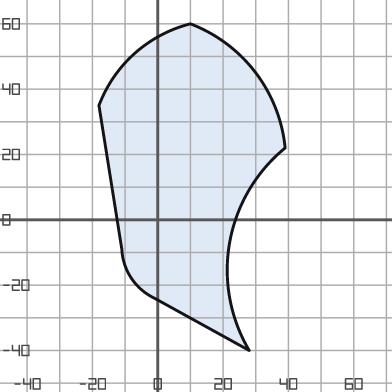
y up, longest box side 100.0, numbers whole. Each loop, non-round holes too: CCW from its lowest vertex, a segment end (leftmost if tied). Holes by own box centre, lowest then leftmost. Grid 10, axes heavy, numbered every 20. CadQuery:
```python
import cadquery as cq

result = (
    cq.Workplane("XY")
    .moveTo(28.0, -40.0)
    .threePointArc((22.0, -7.0), (39.0, 22.0))
    .threePointArc((30.0, 45.0), (10.0, 60.0))
    .threePointArc((-7.0, 51.0), (-18.0, 35.0))
    .lineTo(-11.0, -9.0)
    .threePointArc((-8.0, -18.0), (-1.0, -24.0))
    .close()
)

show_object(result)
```